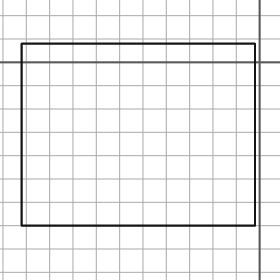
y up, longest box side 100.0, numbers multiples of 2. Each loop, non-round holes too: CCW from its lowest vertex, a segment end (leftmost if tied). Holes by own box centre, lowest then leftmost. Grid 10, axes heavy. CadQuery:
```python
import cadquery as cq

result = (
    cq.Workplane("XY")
    .moveTo(-102.0, -70.0)
    .lineTo(-2.0, -70.0)
    .lineTo(-2.0, 8.0)
    .lineTo(-102.0, 8.0)
    .close()
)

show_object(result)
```